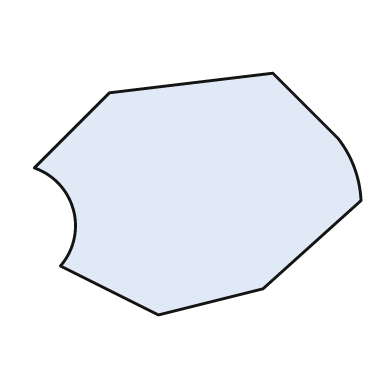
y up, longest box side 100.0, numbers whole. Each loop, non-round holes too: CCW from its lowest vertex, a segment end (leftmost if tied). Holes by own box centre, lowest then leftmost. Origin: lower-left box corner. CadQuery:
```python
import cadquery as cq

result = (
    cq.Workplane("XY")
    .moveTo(38.0, 0.0)
    .lineTo(70.0, 8.0)
    .lineTo(100.0, 35.0)
    .threePointArc((98.0, 45.0), (93.0, 54.0))
    .lineTo(73.0, 74.0)
    .lineTo(23.0, 68.0)
    .lineTo(0.0, 45.0)
    .threePointArc((12.0, 32.0), (8.0, 15.0))
    .close()
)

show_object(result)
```